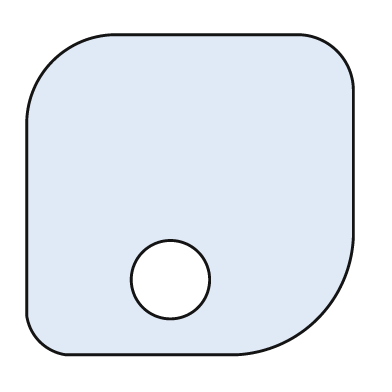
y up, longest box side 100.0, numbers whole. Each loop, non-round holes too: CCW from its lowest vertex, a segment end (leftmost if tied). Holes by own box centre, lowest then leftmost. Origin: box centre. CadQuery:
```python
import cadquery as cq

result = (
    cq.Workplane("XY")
    .moveTo(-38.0, -49.0)
    .lineTo(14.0, -49.0)
    .threePointArc((39.0, -38.0), (50.0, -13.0))
    .lineTo(50.0, 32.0)
    .threePointArc((45.0, 44.0), (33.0, 49.0))
    .lineTo(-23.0, 49.0)
    .threePointArc((-42.0, 41.0), (-50.0, 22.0))
    .lineTo(-50.0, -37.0)
    .threePointArc((-46.0, -45.0), (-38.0, -49.0))
    .close()
    .moveTo(-6.0, -26.0)
    .circle(12.0)
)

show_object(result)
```